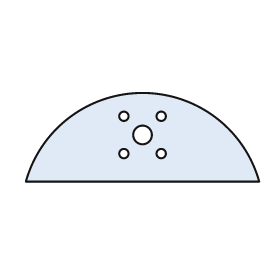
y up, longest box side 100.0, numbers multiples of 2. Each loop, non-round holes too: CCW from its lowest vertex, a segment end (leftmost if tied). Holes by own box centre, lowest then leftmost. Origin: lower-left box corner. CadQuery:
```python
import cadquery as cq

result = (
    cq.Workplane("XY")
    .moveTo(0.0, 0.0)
    .lineTo(100.0, 0.0)
    .threePointArc((50.0, 38.0), (0.0, 0.0))
    .close()
    .moveTo(42.0, 12.0)
    .circle(2.0)
    .moveTo(58.0, 12.0)
    .circle(2.0)
    .moveTo(50.0, 20.0)
    .circle(4.0)
    .moveTo(42.0, 28.0)
    .circle(2.0)
    .moveTo(58.0, 28.0)
    .circle(2.0)
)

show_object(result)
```